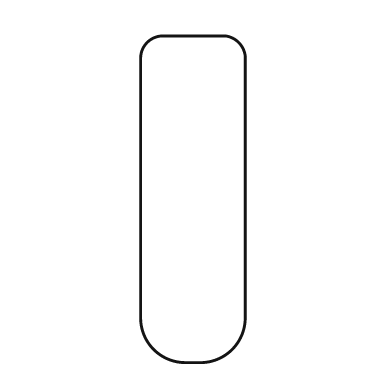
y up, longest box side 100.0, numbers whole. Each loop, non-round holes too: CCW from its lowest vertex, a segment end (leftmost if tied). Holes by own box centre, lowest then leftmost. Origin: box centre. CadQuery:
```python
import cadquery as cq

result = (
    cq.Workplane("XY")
    .moveTo(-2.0, -50.0)
    .lineTo(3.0, -50.0)
    .threePointArc((12.0, -46.0), (16.0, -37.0))
    .lineTo(16.0, 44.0)
    .threePointArc((14.0, 48.0), (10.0, 50.0))
    .lineTo(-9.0, 50.0)
    .threePointArc((-14.0, 48.0), (-16.0, 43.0))
    .lineTo(-16.0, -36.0)
    .threePointArc((-12.0, -46.0), (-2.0, -50.0))
    .close()
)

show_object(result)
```